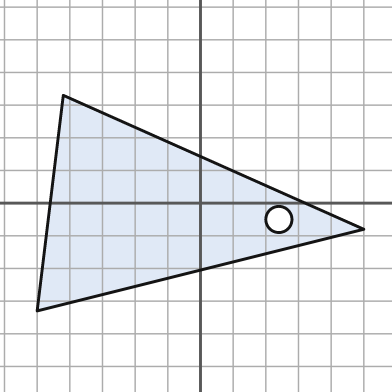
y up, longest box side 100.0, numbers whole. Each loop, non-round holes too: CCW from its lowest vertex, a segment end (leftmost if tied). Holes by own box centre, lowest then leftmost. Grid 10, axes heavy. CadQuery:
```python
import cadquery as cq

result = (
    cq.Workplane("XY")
    .moveTo(-50.0, -33.0)
    .lineTo(50.0, -8.0)
    .lineTo(-42.0, 33.0)
    .close()
    .moveTo(24.0, -5.0)
    .circle(4.0)
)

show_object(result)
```